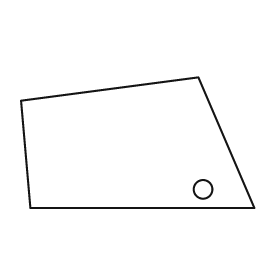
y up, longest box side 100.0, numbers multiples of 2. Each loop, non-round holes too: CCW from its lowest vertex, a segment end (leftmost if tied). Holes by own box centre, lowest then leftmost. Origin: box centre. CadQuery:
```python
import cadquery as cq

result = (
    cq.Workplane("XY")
    .moveTo(-46.0, -28.0)
    .lineTo(50.0, -28.0)
    .lineTo(26.0, 28.0)
    .lineTo(-50.0, 18.0)
    .close()
    .moveTo(28.0, -20.0)
    .circle(4.0)
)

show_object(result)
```